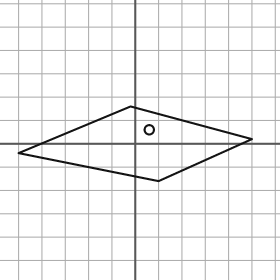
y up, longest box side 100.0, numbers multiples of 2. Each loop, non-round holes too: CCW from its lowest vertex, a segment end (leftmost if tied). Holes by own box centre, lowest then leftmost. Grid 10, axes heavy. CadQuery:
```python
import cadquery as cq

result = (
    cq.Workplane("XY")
    .moveTo(10.0, -16.0)
    .lineTo(50.0, 2.0)
    .lineTo(-2.0, 16.0)
    .lineTo(-50.0, -4.0)
    .close()
    .moveTo(6.0, 6.0)
    .circle(2.0)
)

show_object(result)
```